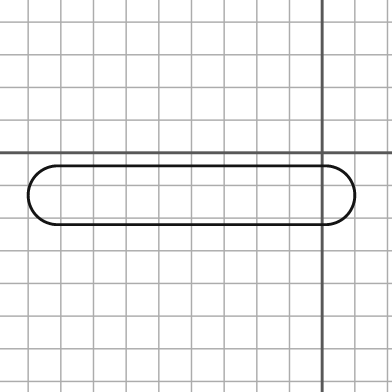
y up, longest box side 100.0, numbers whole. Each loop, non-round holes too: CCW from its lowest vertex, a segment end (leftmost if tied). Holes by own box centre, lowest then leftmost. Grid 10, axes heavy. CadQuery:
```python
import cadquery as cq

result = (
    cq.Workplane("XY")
    .moveTo(-81.0, -22.0)
    .lineTo(1.0, -22.0)
    .threePointArc((10.0, -13.0), (1.0, -4.0))
    .lineTo(-81.0, -4.0)
    .threePointArc((-90.0, -13.0), (-81.0, -22.0))
    .close()
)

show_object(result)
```